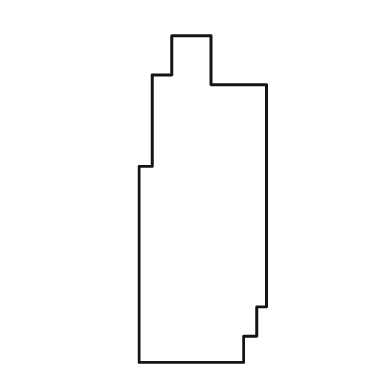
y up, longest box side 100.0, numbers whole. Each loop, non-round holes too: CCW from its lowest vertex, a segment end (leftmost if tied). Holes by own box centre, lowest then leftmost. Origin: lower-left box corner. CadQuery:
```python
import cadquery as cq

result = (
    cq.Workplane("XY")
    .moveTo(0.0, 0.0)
    .lineTo(32.0, 0.0)
    .lineTo(32.0, 8.0)
    .lineTo(36.0, 8.0)
    .lineTo(36.0, 17.0)
    .lineTo(39.0, 17.0)
    .lineTo(39.0, 85.0)
    .lineTo(22.0, 85.0)
    .lineTo(22.0, 100.0)
    .lineTo(10.0, 100.0)
    .lineTo(10.0, 88.0)
    .lineTo(4.0, 88.0)
    .lineTo(4.0, 60.0)
    .lineTo(0.0, 60.0)
    .close()
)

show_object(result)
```